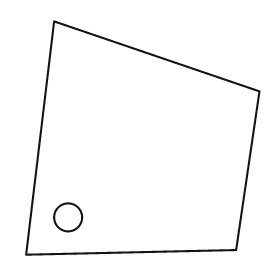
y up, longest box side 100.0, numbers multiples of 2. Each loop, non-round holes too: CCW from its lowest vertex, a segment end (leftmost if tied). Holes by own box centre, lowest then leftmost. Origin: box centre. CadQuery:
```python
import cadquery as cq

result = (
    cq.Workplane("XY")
    .moveTo(-50.0, -50.0)
    .lineTo(40.0, -48.0)
    .lineTo(50.0, 20.0)
    .lineTo(-38.0, 50.0)
    .close()
    .moveTo(-32.0, -34.0)
    .circle(6.0)
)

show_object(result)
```